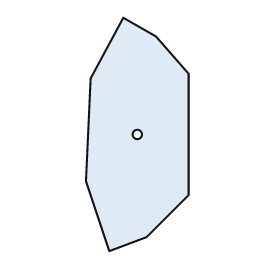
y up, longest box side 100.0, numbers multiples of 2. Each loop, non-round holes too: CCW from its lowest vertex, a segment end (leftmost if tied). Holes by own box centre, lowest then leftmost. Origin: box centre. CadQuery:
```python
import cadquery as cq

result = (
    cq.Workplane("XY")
    .moveTo(-12.0, -50.0)
    .lineTo(4.0, -44.0)
    .lineTo(22.0, -26.0)
    .lineTo(22.0, 26.0)
    .lineTo(8.0, 42.0)
    .lineTo(-6.0, 50.0)
    .lineTo(-20.0, 24.0)
    .lineTo(-22.0, -20.0)
    .close()
    .moveTo(0.0, 0.0)
    .circle(2.0)
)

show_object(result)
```